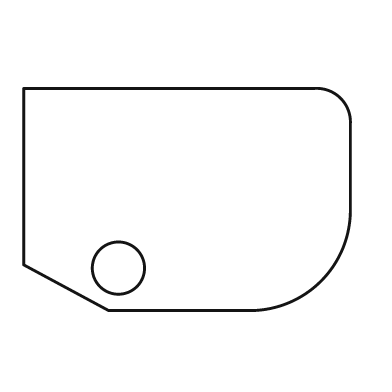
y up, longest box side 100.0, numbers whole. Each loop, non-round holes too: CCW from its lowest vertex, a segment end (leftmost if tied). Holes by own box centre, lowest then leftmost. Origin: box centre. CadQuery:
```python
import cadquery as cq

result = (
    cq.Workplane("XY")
    .moveTo(-24.0, -34.0)
    .lineTo(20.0, -34.0)
    .threePointArc((41.0, -25.0), (50.0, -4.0))
    .lineTo(50.0, 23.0)
    .threePointArc((47.0, 31.0), (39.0, 34.0))
    .lineTo(-50.0, 34.0)
    .lineTo(-50.0, -20.0)
    .close()
    .moveTo(-21.0, -21.0)
    .circle(8.0)
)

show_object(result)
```